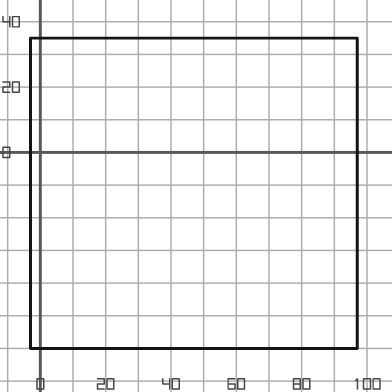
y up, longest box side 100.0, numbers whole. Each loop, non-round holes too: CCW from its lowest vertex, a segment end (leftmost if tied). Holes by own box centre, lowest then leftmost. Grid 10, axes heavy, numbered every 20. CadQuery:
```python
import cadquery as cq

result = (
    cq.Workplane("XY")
    .moveTo(-3.0, -60.0)
    .lineTo(97.0, -60.0)
    .lineTo(97.0, 35.0)
    .lineTo(-3.0, 35.0)
    .close()
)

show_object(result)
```